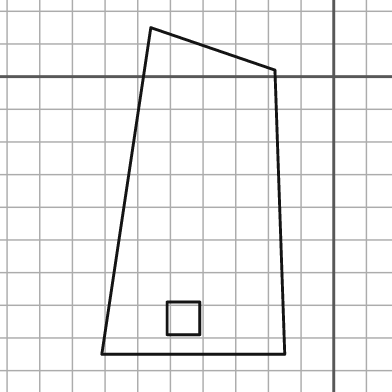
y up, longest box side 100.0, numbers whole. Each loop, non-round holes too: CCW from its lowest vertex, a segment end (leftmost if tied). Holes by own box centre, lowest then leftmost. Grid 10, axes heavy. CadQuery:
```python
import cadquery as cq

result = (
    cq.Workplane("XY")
    .moveTo(-71.0, -85.0)
    .lineTo(-15.0, -85.0)
    .lineTo(-18.0, 2.0)
    .lineTo(-56.0, 15.0)
    .close()
    .moveTo(-51.0, -79.0)
    .lineTo(-41.0, -79.0)
    .lineTo(-41.0, -69.0)
    .lineTo(-51.0, -69.0)
    .close()
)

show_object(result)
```